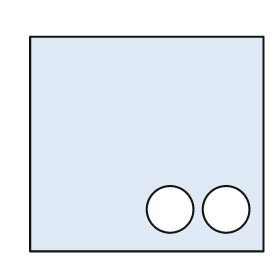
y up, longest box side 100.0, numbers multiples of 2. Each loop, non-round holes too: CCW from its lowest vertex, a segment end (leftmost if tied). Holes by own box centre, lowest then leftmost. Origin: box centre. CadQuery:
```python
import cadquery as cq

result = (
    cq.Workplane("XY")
    .moveTo(-50.0, -46.0)
    .lineTo(50.0, -46.0)
    .lineTo(50.0, 46.0)
    .lineTo(-50.0, 46.0)
    .close()
    .moveTo(10.0, -28.0)
    .circle(10.0)
    .moveTo(34.0, -28.0)
    .circle(10.0)
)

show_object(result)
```